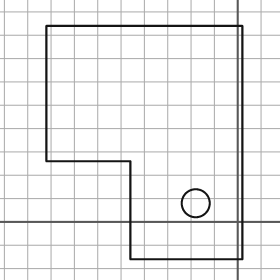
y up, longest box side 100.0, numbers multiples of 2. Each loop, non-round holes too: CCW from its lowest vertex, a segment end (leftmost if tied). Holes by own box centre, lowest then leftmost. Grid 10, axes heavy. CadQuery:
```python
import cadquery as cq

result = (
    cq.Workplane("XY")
    .moveTo(-46.0, -16.0)
    .lineTo(2.0, -16.0)
    .lineTo(2.0, 84.0)
    .lineTo(-82.0, 84.0)
    .lineTo(-82.0, 26.0)
    .lineTo(-46.0, 26.0)
    .close()
    .moveTo(-18.0, 8.0)
    .circle(6.0)
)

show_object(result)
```